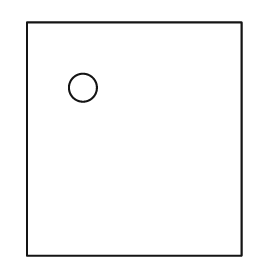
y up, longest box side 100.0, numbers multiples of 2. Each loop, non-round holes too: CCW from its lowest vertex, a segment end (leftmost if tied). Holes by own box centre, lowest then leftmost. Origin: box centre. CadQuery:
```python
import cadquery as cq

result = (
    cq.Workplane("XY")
    .moveTo(-46.0, -50.0)
    .lineTo(46.0, -50.0)
    .lineTo(46.0, 50.0)
    .lineTo(-46.0, 50.0)
    .close()
    .moveTo(-22.0, 22.0)
    .circle(6.0)
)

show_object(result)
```